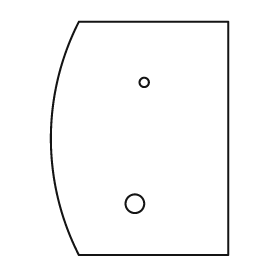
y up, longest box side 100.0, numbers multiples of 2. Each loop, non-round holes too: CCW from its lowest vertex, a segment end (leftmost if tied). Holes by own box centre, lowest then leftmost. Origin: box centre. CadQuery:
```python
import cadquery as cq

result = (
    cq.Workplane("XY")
    .moveTo(-26.0, -50.0)
    .lineTo(38.0, -50.0)
    .lineTo(38.0, 50.0)
    .lineTo(-26.0, 50.0)
    .threePointArc((-38.0, 0.0), (-26.0, -50.0))
    .close()
    .moveTo(-2.0, -28.0)
    .circle(4.0)
    .moveTo(2.0, 24.0)
    .circle(2.0)
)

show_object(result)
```